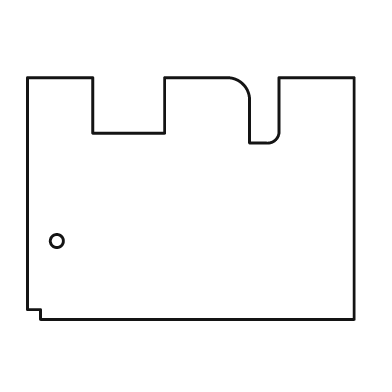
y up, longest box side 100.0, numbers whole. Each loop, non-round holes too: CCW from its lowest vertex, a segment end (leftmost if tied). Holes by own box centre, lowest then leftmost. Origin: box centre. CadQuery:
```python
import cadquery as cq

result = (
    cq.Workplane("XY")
    .moveTo(-46.0, -37.0)
    .lineTo(50.0, -37.0)
    .lineTo(50.0, 37.0)
    .lineTo(27.0, 37.0)
    .lineTo(27.0, 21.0)
    .threePointArc((26.0, 18.0), (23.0, 17.0))
    .lineTo(18.0, 17.0)
    .lineTo(18.0, 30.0)
    .threePointArc((16.0, 35.0), (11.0, 37.0))
    .lineTo(-8.0, 37.0)
    .lineTo(-8.0, 20.0)
    .lineTo(-30.0, 20.0)
    .lineTo(-30.0, 37.0)
    .lineTo(-50.0, 37.0)
    .lineTo(-50.0, -34.0)
    .lineTo(-46.0, -34.0)
    .close()
    .moveTo(-41.0, -13.0)
    .circle(2.0)
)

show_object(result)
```